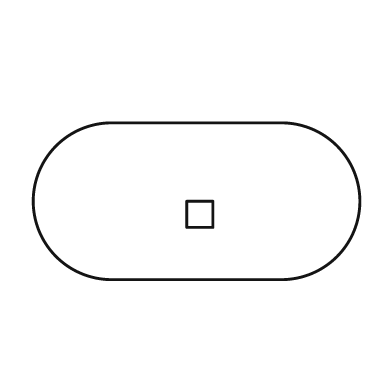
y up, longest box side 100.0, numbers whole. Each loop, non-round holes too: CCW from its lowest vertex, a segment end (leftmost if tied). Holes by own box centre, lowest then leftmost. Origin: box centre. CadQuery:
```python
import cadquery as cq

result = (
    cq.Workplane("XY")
    .moveTo(-26.0, -24.0)
    .lineTo(26.0, -24.0)
    .threePointArc((50.0, 0.0), (26.0, 24.0))
    .lineTo(-26.0, 24.0)
    .threePointArc((-50.0, 0.0), (-26.0, -24.0))
    .close()
    .moveTo(-3.0, -8.0)
    .lineTo(5.0, -8.0)
    .lineTo(5.0, 0.0)
    .lineTo(-3.0, 0.0)
    .close()
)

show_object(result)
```